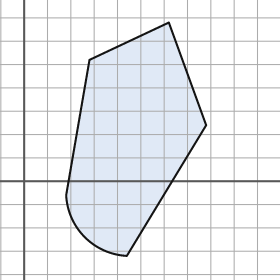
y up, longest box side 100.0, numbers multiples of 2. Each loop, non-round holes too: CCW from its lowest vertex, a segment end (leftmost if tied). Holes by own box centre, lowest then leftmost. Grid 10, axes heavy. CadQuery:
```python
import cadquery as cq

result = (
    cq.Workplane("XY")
    .moveTo(44.0, -32.0)
    .lineTo(78.0, 24.0)
    .lineTo(62.0, 68.0)
    .lineTo(28.0, 52.0)
    .lineTo(18.0, -6.0)
    .threePointArc((26.0, -24.0), (44.0, -32.0))
    .close()
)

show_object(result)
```